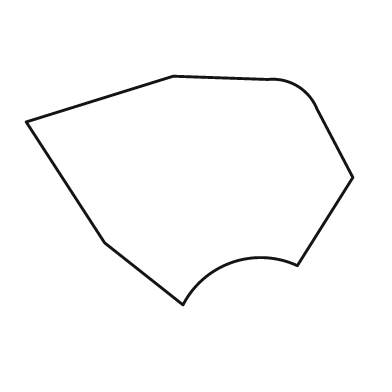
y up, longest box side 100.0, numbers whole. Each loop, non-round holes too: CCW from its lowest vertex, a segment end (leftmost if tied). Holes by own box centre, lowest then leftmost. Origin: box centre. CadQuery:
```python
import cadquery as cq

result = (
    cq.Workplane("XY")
    .moveTo(-2.0, -35.0)
    .threePointArc((13.0, -22.0), (33.0, -23.0))
    .lineTo(50.0, 4.0)
    .lineTo(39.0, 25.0)
    .threePointArc((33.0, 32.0), (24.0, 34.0))
    .lineTo(-5.0, 35.0)
    .lineTo(-50.0, 21.0)
    .lineTo(-26.0, -16.0)
    .close()
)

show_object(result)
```